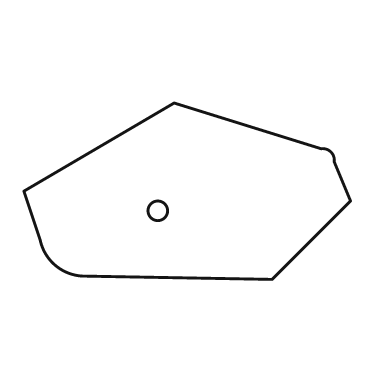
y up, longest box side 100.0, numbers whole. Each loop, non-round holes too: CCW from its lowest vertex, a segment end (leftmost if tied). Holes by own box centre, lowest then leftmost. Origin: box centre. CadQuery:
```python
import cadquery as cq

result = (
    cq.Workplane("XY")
    .moveTo(26.0, -27.0)
    .lineTo(50.0, -3.0)
    .lineTo(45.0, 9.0)
    .threePointArc((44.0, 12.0), (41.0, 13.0))
    .lineTo(-4.0, 27.0)
    .lineTo(-50.0, 0.0)
    .lineTo(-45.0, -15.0)
    .threePointArc((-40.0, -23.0), (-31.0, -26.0))
    .close()
    .moveTo(-9.0, -6.0)
    .circle(3.0)
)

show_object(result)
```